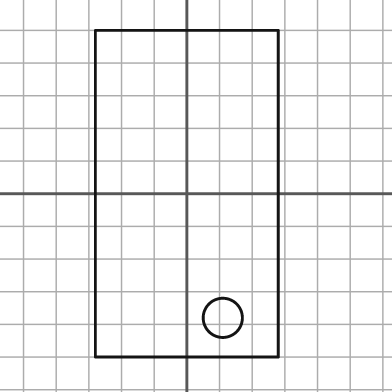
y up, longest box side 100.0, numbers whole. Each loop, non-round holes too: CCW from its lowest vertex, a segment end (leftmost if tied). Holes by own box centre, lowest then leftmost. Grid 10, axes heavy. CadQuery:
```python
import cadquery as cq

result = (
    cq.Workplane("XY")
    .moveTo(-28.0, -50.0)
    .lineTo(28.0, -50.0)
    .lineTo(28.0, 50.0)
    .lineTo(-28.0, 50.0)
    .close()
    .moveTo(11.0, -38.0)
    .circle(6.0)
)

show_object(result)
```